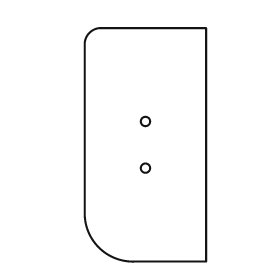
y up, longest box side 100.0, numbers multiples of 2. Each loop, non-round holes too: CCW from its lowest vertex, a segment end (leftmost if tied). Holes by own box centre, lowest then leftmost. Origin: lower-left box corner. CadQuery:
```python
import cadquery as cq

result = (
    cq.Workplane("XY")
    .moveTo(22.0, 0.0)
    .lineTo(52.0, 0.0)
    .lineTo(52.0, 100.0)
    .lineTo(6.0, 100.0)
    .threePointArc((2.0, 98.0), (0.0, 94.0))
    .lineTo(0.0, 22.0)
    .threePointArc((6.0, 6.0), (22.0, 0.0))
    .close()
    .moveTo(26.0, 40.0)
    .circle(2.0)
    .moveTo(26.0, 60.0)
    .circle(2.0)
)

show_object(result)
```